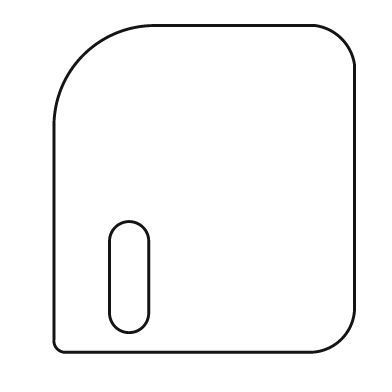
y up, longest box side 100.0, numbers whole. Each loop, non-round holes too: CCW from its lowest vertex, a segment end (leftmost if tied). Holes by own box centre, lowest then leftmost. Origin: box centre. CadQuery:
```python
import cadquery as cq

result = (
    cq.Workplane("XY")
    .moveTo(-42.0, -50.0)
    .lineTo(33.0, -50.0)
    .threePointArc((42.0, -46.0), (46.0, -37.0))
    .lineTo(46.0, 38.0)
    .threePointArc((42.0, 46.0), (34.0, 50.0))
    .lineTo(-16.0, 50.0)
    .threePointArc((-37.0, 41.0), (-46.0, 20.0))
    .lineTo(-46.0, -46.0)
    .threePointArc((-45.0, -49.0), (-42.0, -50.0))
    .close()
    .moveTo(-29.0, -38.0)
    .threePointArc((-23.0, -44.0), (-17.0, -38.0))
    .lineTo(-17.0, -16.0)
    .threePointArc((-23.0, -10.0), (-29.0, -16.0))
    .close()
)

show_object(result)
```